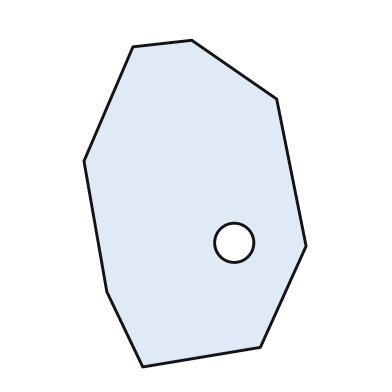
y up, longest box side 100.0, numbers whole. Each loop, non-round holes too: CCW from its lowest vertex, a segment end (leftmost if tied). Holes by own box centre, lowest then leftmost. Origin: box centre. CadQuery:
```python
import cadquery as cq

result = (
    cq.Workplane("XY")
    .moveTo(-16.0, -50.0)
    .lineTo(20.0, -44.0)
    .lineTo(34.0, -13.0)
    .lineTo(25.0, 32.0)
    .lineTo(-1.0, 50.0)
    .lineTo(-19.0, 48.0)
    .lineTo(-34.0, 13.0)
    .lineTo(-27.0, -27.0)
    .close()
    .moveTo(12.0, -12.0)
    .circle(6.0)
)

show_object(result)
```